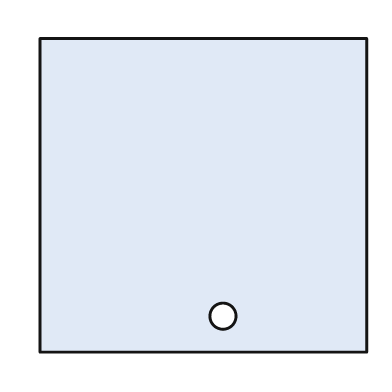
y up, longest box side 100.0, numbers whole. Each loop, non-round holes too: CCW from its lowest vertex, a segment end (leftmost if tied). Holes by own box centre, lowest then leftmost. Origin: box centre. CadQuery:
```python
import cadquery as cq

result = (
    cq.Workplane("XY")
    .moveTo(-50.0, -48.0)
    .lineTo(50.0, -48.0)
    .lineTo(50.0, 48.0)
    .lineTo(-50.0, 48.0)
    .close()
    .moveTo(6.0, -37.0)
    .circle(4.0)
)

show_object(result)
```